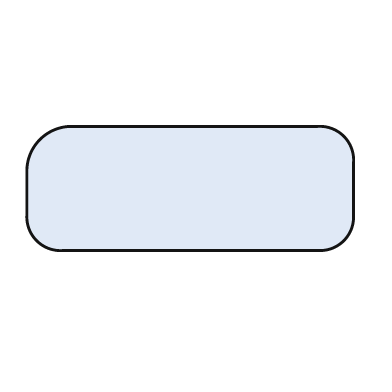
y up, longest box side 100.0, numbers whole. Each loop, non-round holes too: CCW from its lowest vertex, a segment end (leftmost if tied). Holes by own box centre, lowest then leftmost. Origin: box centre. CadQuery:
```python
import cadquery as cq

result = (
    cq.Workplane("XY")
    .moveTo(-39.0, -19.0)
    .lineTo(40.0, -19.0)
    .threePointArc((47.0, -16.0), (50.0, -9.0))
    .lineTo(50.0, 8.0)
    .threePointArc((47.0, 16.0), (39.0, 19.0))
    .lineTo(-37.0, 19.0)
    .threePointArc((-46.0, 15.0), (-50.0, 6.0))
    .lineTo(-50.0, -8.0)
    .threePointArc((-47.0, -16.0), (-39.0, -19.0))
    .close()
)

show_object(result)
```